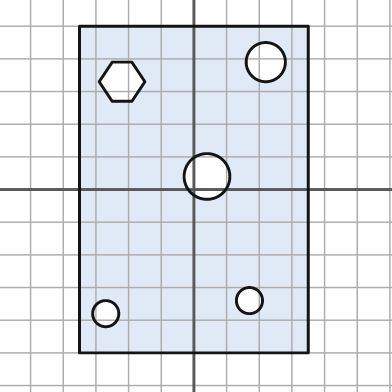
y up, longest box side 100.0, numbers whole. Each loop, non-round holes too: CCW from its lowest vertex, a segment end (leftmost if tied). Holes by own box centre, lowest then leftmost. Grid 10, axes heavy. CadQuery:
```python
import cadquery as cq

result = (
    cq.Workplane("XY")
    .moveTo(-35.0, -50.0)
    .lineTo(35.0, -50.0)
    .lineTo(35.0, 50.0)
    .lineTo(-35.0, 50.0)
    .close()
    .moveTo(-27.0, -38.0)
    .circle(4.0)
    .moveTo(17.0, -34.0)
    .circle(4.0)
    .moveTo(4.0, 4.0)
    .circle(7.0)
    .moveTo(-25.0, 27.0)
    .lineTo(-19.0, 27.0)
    .lineTo(-15.0, 33.0)
    .lineTo(-19.0, 39.0)
    .lineTo(-25.0, 39.0)
    .lineTo(-29.0, 33.0)
    .close()
    .moveTo(22.0, 39.0)
    .circle(6.0)
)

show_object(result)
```